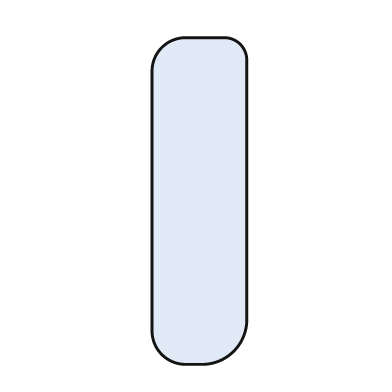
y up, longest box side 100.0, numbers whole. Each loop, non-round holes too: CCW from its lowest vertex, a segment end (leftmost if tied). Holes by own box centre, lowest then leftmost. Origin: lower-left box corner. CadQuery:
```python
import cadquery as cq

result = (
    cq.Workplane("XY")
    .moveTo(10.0, 0.0)
    .lineTo(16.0, 0.0)
    .threePointArc((25.0, 4.0), (29.0, 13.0))
    .lineTo(29.0, 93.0)
    .threePointArc((27.0, 98.0), (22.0, 100.0))
    .lineTo(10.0, 100.0)
    .threePointArc((3.0, 97.0), (0.0, 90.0))
    .lineTo(0.0, 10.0)
    .threePointArc((3.0, 3.0), (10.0, 0.0))
    .close()
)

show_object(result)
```